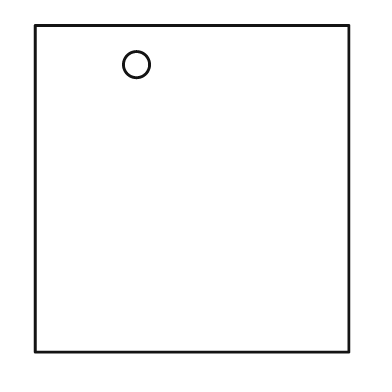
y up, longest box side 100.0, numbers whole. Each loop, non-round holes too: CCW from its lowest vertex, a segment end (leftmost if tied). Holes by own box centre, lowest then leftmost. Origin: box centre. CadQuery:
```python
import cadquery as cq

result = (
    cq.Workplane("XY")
    .moveTo(-48.0, -50.0)
    .lineTo(48.0, -50.0)
    .lineTo(48.0, 50.0)
    .lineTo(-48.0, 50.0)
    .close()
    .moveTo(-17.0, 38.0)
    .circle(4.0)
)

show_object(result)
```